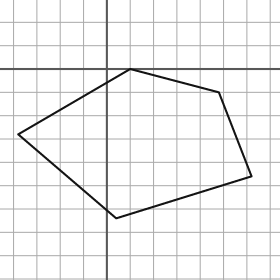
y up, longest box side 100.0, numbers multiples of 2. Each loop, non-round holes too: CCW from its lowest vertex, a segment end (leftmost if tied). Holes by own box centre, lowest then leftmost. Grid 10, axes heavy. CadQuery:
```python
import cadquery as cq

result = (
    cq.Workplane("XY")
    .moveTo(4.0, -64.0)
    .lineTo(62.0, -46.0)
    .lineTo(48.0, -10.0)
    .lineTo(10.0, 0.0)
    .lineTo(-38.0, -28.0)
    .close()
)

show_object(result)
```